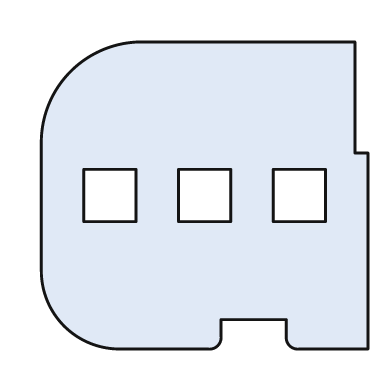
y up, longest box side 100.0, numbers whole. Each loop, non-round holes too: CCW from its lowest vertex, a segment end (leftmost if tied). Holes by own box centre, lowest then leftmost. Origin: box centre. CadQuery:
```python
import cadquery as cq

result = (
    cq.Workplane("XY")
    .moveTo(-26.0, -47.0)
    .lineTo(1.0, -47.0)
    .threePointArc((4.0, -46.0), (5.0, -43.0))
    .lineTo(5.0, -38.0)
    .lineTo(25.0, -38.0)
    .lineTo(25.0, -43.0)
    .threePointArc((26.0, -46.0), (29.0, -47.0))
    .lineTo(50.0, -47.0)
    .lineTo(50.0, 13.0)
    .lineTo(46.0, 13.0)
    .lineTo(46.0, 47.0)
    .lineTo(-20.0, 47.0)
    .threePointArc((-41.0, 38.0), (-50.0, 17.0))
    .lineTo(-50.0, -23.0)
    .threePointArc((-43.0, -40.0), (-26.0, -47.0))
    .close()
    .moveTo(-37.0, -8.0)
    .lineTo(-21.0, -8.0)
    .lineTo(-21.0, 8.0)
    .lineTo(-37.0, 8.0)
    .close()
    .moveTo(-8.0, -8.0)
    .lineTo(8.0, -8.0)
    .lineTo(8.0, 8.0)
    .lineTo(-8.0, 8.0)
    .close()
    .moveTo(21.0, -8.0)
    .lineTo(37.0, -8.0)
    .lineTo(37.0, 8.0)
    .lineTo(21.0, 8.0)
    .close()
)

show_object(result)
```